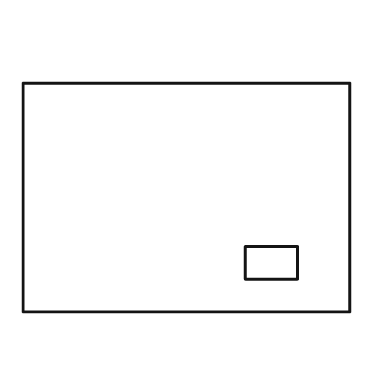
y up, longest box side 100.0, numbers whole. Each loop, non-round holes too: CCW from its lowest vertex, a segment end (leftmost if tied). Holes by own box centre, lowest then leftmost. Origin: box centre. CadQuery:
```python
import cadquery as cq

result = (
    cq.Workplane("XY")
    .moveTo(-50.0, -35.0)
    .lineTo(50.0, -35.0)
    .lineTo(50.0, 35.0)
    .lineTo(-50.0, 35.0)
    .close()
    .moveTo(18.0, -25.0)
    .lineTo(34.0, -25.0)
    .lineTo(34.0, -15.0)
    .lineTo(18.0, -15.0)
    .close()
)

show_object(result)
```